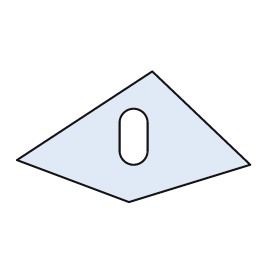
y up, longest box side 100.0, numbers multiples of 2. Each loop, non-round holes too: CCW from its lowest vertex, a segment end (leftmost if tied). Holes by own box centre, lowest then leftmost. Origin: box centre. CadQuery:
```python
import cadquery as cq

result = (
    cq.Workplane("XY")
    .moveTo(-2.0, -28.0)
    .lineTo(50.0, -12.0)
    .lineTo(8.0, 28.0)
    .lineTo(-50.0, -10.0)
    .close()
    .moveTo(-6.0, -6.0)
    .threePointArc((0.0, -12.0), (6.0, -6.0))
    .lineTo(6.0, 6.0)
    .threePointArc((0.0, 12.0), (-6.0, 6.0))
    .close()
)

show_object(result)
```